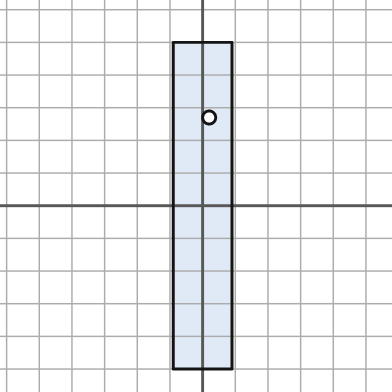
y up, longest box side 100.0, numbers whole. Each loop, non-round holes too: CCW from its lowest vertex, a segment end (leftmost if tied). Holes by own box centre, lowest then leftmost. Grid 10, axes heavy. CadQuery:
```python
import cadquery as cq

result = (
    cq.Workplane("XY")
    .moveTo(-9.0, -50.0)
    .lineTo(9.0, -50.0)
    .lineTo(9.0, 50.0)
    .lineTo(-9.0, 50.0)
    .close()
    .moveTo(2.0, 27.0)
    .circle(2.0)
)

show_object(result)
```